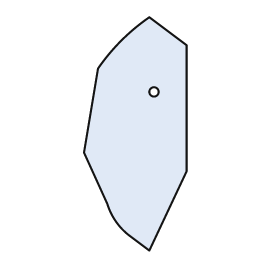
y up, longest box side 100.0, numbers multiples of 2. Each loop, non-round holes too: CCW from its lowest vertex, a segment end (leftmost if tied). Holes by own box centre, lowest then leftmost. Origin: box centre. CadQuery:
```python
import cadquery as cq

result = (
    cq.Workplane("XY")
    .moveTo(6.0, -50.0)
    .lineTo(22.0, -16.0)
    .lineTo(22.0, 38.0)
    .lineTo(6.0, 50.0)
    .threePointArc((-6.0, 40.0), (-16.0, 28.0))
    .lineTo(-22.0, -8.0)
    .lineTo(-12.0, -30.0)
    .threePointArc((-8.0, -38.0), (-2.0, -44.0))
    .close()
    .moveTo(8.0, 18.0)
    .circle(2.0)
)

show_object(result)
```